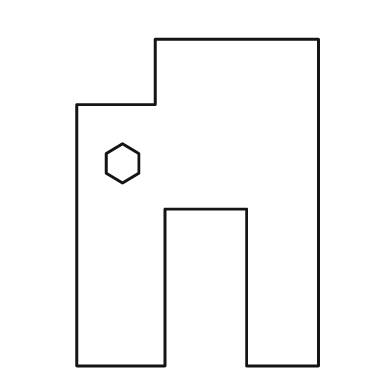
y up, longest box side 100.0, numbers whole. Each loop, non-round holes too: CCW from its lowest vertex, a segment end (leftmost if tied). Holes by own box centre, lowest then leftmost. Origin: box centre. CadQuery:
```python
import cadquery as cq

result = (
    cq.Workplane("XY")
    .moveTo(-37.0, -50.0)
    .lineTo(-10.0, -50.0)
    .lineTo(-10.0, -2.0)
    .lineTo(15.0, -2.0)
    .lineTo(15.0, -50.0)
    .lineTo(37.0, -50.0)
    .lineTo(37.0, 50.0)
    .lineTo(-13.0, 50.0)
    .lineTo(-13.0, 30.0)
    .lineTo(-37.0, 30.0)
    .close()
    .moveTo(-23.0, 6.0)
    .lineTo(-18.0, 9.0)
    .lineTo(-18.0, 15.0)
    .lineTo(-23.0, 18.0)
    .lineTo(-28.0, 15.0)
    .lineTo(-28.0, 9.0)
    .close()
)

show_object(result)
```